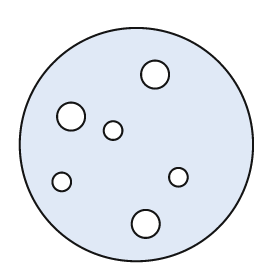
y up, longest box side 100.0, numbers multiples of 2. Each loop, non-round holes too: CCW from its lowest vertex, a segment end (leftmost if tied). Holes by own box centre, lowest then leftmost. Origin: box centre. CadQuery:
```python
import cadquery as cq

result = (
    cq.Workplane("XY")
    .moveTo(0.0, 0.0)
    .circle(50.0)
    .moveTo(4.0, -34.0)
    .circle(6.0)
    .moveTo(-32.0, -16.0)
    .circle(4.0)
    .moveTo(18.0, -14.0)
    .circle(4.0)
    .moveTo(-10.0, 6.0)
    .circle(4.0)
    .moveTo(-28.0, 12.0)
    .circle(6.0)
    .moveTo(8.0, 30.0)
    .circle(6.0)
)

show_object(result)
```